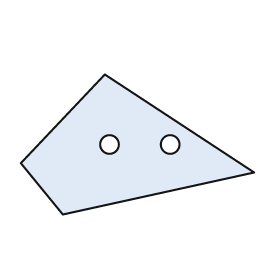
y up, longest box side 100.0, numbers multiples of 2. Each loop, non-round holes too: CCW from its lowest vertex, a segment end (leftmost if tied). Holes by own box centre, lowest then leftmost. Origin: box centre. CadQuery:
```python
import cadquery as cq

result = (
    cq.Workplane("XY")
    .moveTo(-32.0, -30.0)
    .lineTo(50.0, -12.0)
    .lineTo(-14.0, 30.0)
    .lineTo(-50.0, -8.0)
    .close()
    .moveTo(-12.0, 0.0)
    .circle(4.0)
    .moveTo(14.0, 0.0)
    .circle(4.0)
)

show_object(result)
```